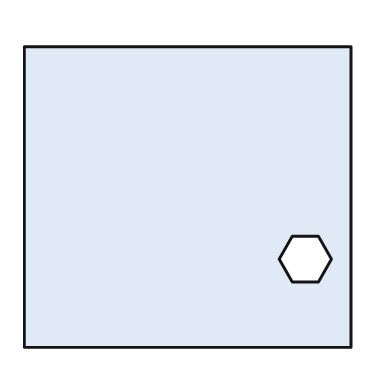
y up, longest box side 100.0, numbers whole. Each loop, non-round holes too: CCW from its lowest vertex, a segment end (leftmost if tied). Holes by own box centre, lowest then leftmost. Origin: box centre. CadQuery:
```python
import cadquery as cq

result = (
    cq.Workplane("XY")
    .moveTo(-50.0, -46.0)
    .lineTo(50.0, -46.0)
    .lineTo(50.0, 46.0)
    .lineTo(-50.0, 46.0)
    .close()
    .moveTo(32.0, -26.0)
    .lineTo(40.0, -26.0)
    .lineTo(44.0, -19.0)
    .lineTo(40.0, -12.0)
    .lineTo(32.0, -12.0)
    .lineTo(28.0, -19.0)
    .close()
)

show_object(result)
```